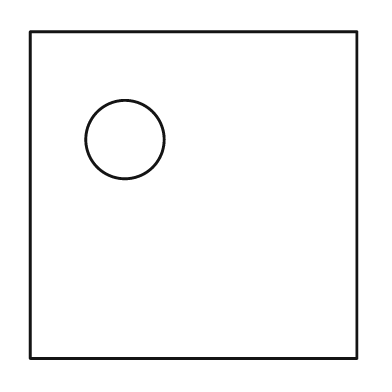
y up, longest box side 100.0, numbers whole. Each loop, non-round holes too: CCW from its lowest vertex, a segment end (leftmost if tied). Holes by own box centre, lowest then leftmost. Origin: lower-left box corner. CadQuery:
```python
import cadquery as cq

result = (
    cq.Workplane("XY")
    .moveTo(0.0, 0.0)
    .lineTo(100.0, 0.0)
    .lineTo(100.0, 100.0)
    .lineTo(0.0, 100.0)
    .close()
    .moveTo(29.0, 67.0)
    .circle(12.0)
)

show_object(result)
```